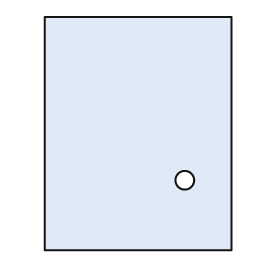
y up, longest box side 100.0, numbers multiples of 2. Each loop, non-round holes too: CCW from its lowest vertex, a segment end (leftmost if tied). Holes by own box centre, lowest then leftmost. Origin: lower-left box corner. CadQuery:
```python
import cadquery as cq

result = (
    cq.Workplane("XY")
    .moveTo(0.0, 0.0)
    .lineTo(80.0, 0.0)
    .lineTo(80.0, 100.0)
    .lineTo(0.0, 100.0)
    .close()
    .moveTo(60.0, 30.0)
    .circle(4.0)
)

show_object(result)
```